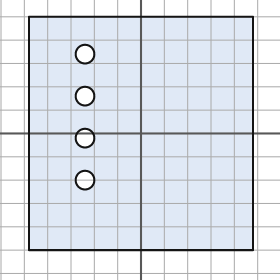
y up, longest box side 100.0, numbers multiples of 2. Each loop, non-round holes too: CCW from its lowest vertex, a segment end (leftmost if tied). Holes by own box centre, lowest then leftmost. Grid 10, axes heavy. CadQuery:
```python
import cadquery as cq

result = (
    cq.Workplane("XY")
    .moveTo(-48.0, -50.0)
    .lineTo(48.0, -50.0)
    .lineTo(48.0, 50.0)
    .lineTo(-48.0, 50.0)
    .close()
    .moveTo(-24.0, -20.0)
    .circle(4.0)
    .moveTo(-24.0, -2.0)
    .circle(4.0)
    .moveTo(-24.0, 16.0)
    .circle(4.0)
    .moveTo(-24.0, 34.0)
    .circle(4.0)
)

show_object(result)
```